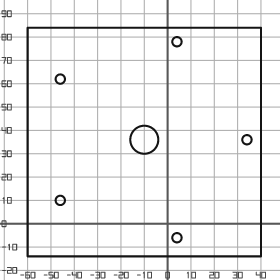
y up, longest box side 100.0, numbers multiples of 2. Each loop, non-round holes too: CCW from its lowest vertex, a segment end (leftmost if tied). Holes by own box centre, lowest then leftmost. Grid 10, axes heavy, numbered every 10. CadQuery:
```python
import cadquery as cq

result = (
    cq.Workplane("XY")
    .moveTo(-60.0, -14.0)
    .lineTo(40.0, -14.0)
    .lineTo(40.0, 84.0)
    .lineTo(-60.0, 84.0)
    .close()
    .moveTo(4.0, -6.0)
    .circle(2.0)
    .moveTo(-46.0, 10.0)
    .circle(2.0)
    .moveTo(-10.0, 36.0)
    .circle(6.0)
    .moveTo(34.0, 36.0)
    .circle(2.0)
    .moveTo(-46.0, 62.0)
    .circle(2.0)
    .moveTo(4.0, 78.0)
    .circle(2.0)
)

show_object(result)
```